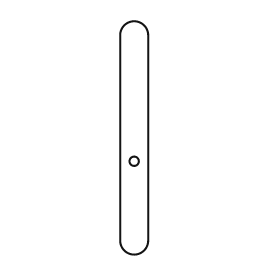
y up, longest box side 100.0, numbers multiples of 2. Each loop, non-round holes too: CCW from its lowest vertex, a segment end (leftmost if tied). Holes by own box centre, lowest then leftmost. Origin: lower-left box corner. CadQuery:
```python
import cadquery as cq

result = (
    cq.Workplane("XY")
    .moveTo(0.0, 6.0)
    .threePointArc((6.0, 0.0), (12.0, 6.0))
    .lineTo(12.0, 94.0)
    .threePointArc((6.0, 100.0), (0.0, 94.0))
    .close()
    .moveTo(6.0, 40.0)
    .circle(2.0)
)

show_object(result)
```